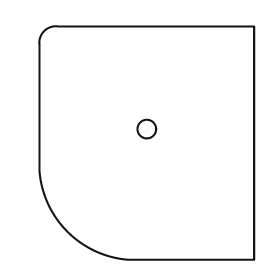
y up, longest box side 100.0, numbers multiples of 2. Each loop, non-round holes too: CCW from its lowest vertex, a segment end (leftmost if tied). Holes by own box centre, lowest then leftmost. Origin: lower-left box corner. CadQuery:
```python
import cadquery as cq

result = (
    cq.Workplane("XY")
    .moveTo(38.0, 0.0)
    .lineTo(92.0, 0.0)
    .lineTo(92.0, 100.0)
    .lineTo(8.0, 100.0)
    .threePointArc((2.0, 98.0), (0.0, 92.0))
    .lineTo(0.0, 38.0)
    .threePointArc((12.0, 12.0), (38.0, 0.0))
    .close()
    .moveTo(46.0, 56.0)
    .circle(4.0)
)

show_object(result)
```